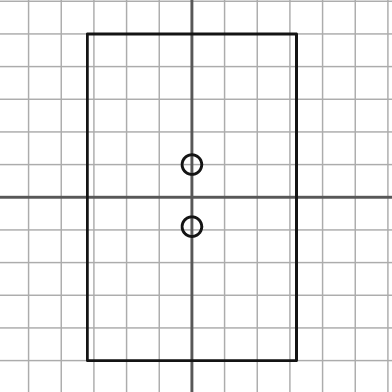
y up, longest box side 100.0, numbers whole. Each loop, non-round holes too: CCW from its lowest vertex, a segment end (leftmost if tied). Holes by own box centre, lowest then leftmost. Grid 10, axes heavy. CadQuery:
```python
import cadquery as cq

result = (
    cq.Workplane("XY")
    .moveTo(-32.0, -50.0)
    .lineTo(32.0, -50.0)
    .lineTo(32.0, 50.0)
    .lineTo(-32.0, 50.0)
    .close()
    .moveTo(0.0, -9.0)
    .circle(3.0)
    .moveTo(0.0, 10.0)
    .circle(3.0)
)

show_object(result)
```